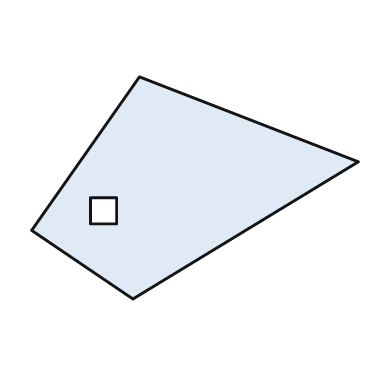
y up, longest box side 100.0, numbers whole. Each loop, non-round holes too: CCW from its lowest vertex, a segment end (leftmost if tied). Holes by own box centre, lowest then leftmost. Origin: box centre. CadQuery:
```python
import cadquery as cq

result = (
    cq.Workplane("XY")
    .moveTo(-19.0, -34.0)
    .lineTo(50.0, 8.0)
    .lineTo(-17.0, 34.0)
    .lineTo(-50.0, -13.0)
    .close()
    .moveTo(-32.0, -11.0)
    .lineTo(-24.0, -11.0)
    .lineTo(-24.0, -3.0)
    .lineTo(-32.0, -3.0)
    .close()
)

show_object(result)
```